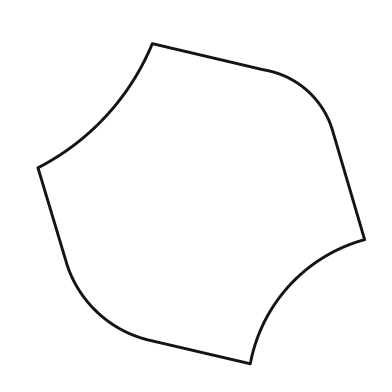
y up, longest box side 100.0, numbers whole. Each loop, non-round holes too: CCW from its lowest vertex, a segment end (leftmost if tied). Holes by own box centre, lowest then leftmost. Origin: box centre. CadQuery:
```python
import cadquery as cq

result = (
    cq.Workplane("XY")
    .moveTo(15.0, -49.0)
    .threePointArc((27.0, -25.0), (50.0, -11.0))
    .lineTo(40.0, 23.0)
    .threePointArc((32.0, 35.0), (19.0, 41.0))
    .lineTo(-15.0, 49.0)
    .threePointArc((-29.0, 27.0), (-50.0, 11.0))
    .lineTo(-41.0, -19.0)
    .threePointArc((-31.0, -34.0), (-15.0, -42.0))
    .close()
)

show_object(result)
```